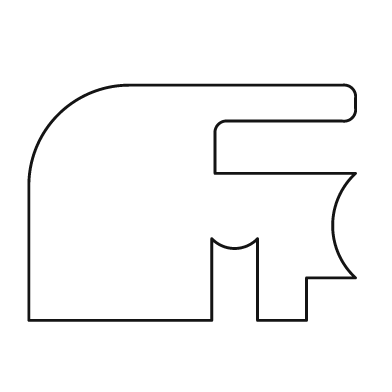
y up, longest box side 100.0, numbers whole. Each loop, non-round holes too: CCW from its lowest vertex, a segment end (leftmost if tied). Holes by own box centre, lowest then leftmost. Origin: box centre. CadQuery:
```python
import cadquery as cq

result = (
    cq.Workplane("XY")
    .moveTo(-50.0, -36.0)
    .lineTo(6.0, -36.0)
    .lineTo(6.0, -11.0)
    .threePointArc((13.0, -14.0), (20.0, -11.0))
    .lineTo(20.0, -36.0)
    .lineTo(35.0, -36.0)
    .lineTo(35.0, -23.0)
    .lineTo(50.0, -23.0)
    .threePointArc((43.0, -7.0), (50.0, 9.0))
    .lineTo(7.0, 9.0)
    .lineTo(7.0, 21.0)
    .threePointArc((8.0, 24.0), (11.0, 25.0))
    .lineTo(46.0, 25.0)
    .threePointArc((49.0, 26.0), (50.0, 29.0))
    .lineTo(50.0, 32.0)
    .threePointArc((49.0, 35.0), (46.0, 36.0))
    .lineTo(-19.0, 36.0)
    .threePointArc((-41.0, 27.0), (-50.0, 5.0))
    .close()
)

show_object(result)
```